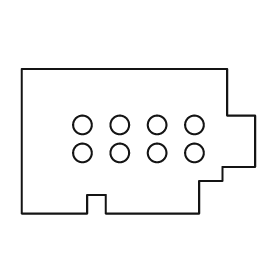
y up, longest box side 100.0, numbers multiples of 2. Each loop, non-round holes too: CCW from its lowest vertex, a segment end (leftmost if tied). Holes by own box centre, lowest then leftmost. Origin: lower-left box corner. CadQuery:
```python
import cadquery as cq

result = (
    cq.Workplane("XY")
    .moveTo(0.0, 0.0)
    .lineTo(28.0, 0.0)
    .lineTo(28.0, 8.0)
    .lineTo(36.0, 8.0)
    .lineTo(36.0, 0.0)
    .lineTo(76.0, 0.0)
    .lineTo(76.0, 14.0)
    .lineTo(86.0, 14.0)
    .lineTo(86.0, 20.0)
    .lineTo(100.0, 20.0)
    .lineTo(100.0, 42.0)
    .lineTo(88.0, 42.0)
    .lineTo(88.0, 62.0)
    .lineTo(0.0, 62.0)
    .close()
    .moveTo(26.0, 26.0)
    .circle(4.0)
    .moveTo(42.0, 26.0)
    .circle(4.0)
    .moveTo(58.0, 26.0)
    .circle(4.0)
    .moveTo(74.0, 26.0)
    .circle(4.0)
    .moveTo(26.0, 38.0)
    .circle(4.0)
    .moveTo(42.0, 38.0)
    .circle(4.0)
    .moveTo(58.0, 38.0)
    .circle(4.0)
    .moveTo(74.0, 38.0)
    .circle(4.0)
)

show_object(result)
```